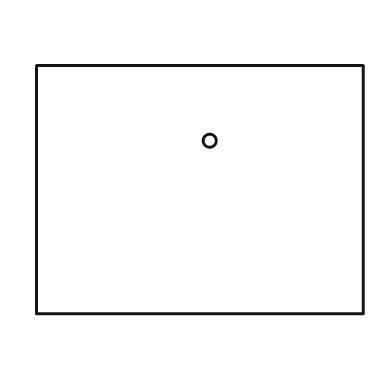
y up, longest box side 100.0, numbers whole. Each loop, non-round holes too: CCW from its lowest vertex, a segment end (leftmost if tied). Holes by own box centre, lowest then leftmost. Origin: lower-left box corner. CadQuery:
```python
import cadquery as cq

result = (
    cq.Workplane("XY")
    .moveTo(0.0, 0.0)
    .lineTo(100.0, 0.0)
    .lineTo(100.0, 76.0)
    .lineTo(0.0, 76.0)
    .close()
    .moveTo(53.0, 53.0)
    .circle(2.0)
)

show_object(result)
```